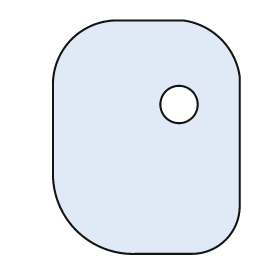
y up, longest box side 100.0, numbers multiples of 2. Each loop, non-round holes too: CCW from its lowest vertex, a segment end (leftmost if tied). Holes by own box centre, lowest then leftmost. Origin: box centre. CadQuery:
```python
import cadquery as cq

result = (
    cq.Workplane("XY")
    .moveTo(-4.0, -50.0)
    .lineTo(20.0, -50.0)
    .threePointArc((34.0, -44.0), (40.0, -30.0))
    .lineTo(40.0, 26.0)
    .threePointArc((32.0, 42.0), (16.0, 50.0))
    .lineTo(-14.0, 50.0)
    .threePointArc((-32.0, 42.0), (-40.0, 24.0))
    .lineTo(-40.0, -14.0)
    .threePointArc((-30.0, -40.0), (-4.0, -50.0))
    .close()
    .moveTo(14.0, 14.0)
    .circle(8.0)
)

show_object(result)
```